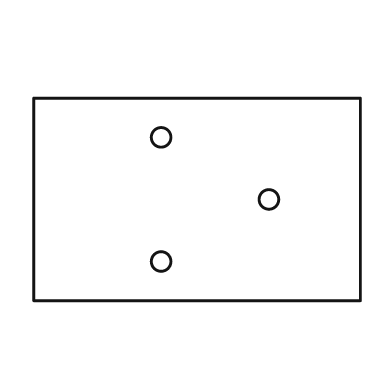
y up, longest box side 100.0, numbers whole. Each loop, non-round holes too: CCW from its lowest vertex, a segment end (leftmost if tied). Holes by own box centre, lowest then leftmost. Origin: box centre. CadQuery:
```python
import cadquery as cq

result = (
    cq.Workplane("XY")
    .moveTo(-50.0, -31.0)
    .lineTo(50.0, -31.0)
    .lineTo(50.0, 31.0)
    .lineTo(-50.0, 31.0)
    .close()
    .moveTo(-11.0, -19.0)
    .circle(3.0)
    .moveTo(22.0, 0.0)
    .circle(3.0)
    .moveTo(-11.0, 19.0)
    .circle(3.0)
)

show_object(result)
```